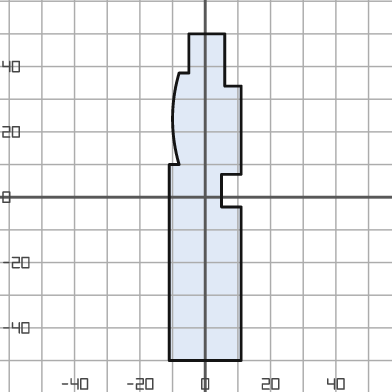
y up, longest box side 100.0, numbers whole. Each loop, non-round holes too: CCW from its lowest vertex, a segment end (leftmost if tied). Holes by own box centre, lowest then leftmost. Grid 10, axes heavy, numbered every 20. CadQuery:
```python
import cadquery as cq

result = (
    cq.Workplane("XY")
    .moveTo(-11.0, -50.0)
    .lineTo(11.0, -50.0)
    .lineTo(11.0, -3.0)
    .lineTo(5.0, -3.0)
    .lineTo(5.0, 7.0)
    .lineTo(11.0, 7.0)
    .lineTo(11.0, 34.0)
    .lineTo(6.0, 34.0)
    .lineTo(6.0, 50.0)
    .lineTo(-5.0, 50.0)
    .lineTo(-5.0, 38.0)
    .lineTo(-8.0, 38.0)
    .threePointArc((-10.0, 24.0), (-8.0, 10.0))
    .lineTo(-11.0, 10.0)
    .close()
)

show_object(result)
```